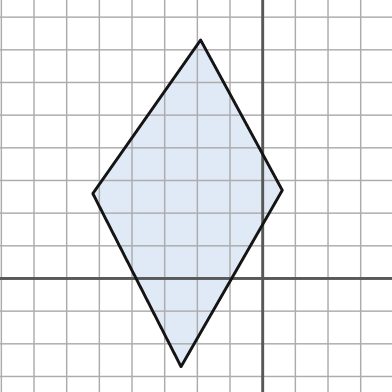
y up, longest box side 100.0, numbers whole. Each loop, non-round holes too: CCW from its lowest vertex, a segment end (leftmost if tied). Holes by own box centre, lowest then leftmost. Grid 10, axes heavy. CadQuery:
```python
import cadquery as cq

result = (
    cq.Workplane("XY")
    .moveTo(-25.0, -27.0)
    .lineTo(6.0, 27.0)
    .lineTo(-19.0, 73.0)
    .lineTo(-52.0, 26.0)
    .close()
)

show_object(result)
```